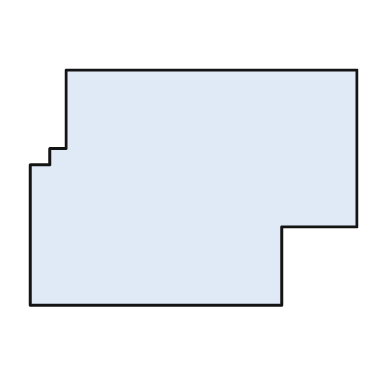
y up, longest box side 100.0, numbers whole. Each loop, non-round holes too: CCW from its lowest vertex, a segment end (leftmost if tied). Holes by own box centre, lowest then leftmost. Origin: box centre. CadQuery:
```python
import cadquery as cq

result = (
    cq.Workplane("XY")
    .moveTo(-50.0, -36.0)
    .lineTo(27.0, -36.0)
    .lineTo(27.0, -12.0)
    .lineTo(50.0, -12.0)
    .lineTo(50.0, 36.0)
    .lineTo(-39.0, 36.0)
    .lineTo(-39.0, 12.0)
    .lineTo(-44.0, 12.0)
    .lineTo(-44.0, 7.0)
    .lineTo(-50.0, 7.0)
    .close()
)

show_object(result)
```